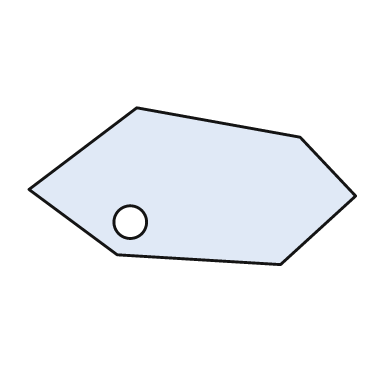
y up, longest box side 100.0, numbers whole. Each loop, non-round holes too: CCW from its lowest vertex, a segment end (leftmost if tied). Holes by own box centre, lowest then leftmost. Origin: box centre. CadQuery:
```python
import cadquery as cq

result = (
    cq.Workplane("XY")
    .moveTo(27.0, -24.0)
    .lineTo(50.0, -3.0)
    .lineTo(33.0, 15.0)
    .lineTo(-17.0, 24.0)
    .lineTo(-50.0, -1.0)
    .lineTo(-23.0, -21.0)
    .close()
    .moveTo(-19.0, -11.0)
    .circle(5.0)
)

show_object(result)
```